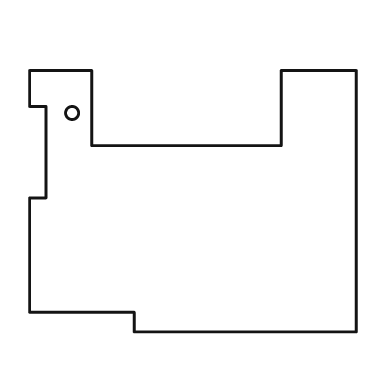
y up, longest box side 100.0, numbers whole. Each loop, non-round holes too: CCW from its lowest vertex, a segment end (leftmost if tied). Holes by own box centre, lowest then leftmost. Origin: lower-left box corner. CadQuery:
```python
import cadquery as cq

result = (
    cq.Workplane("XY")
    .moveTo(32.0, 0.0)
    .lineTo(100.0, 0.0)
    .lineTo(100.0, 80.0)
    .lineTo(77.0, 80.0)
    .lineTo(77.0, 57.0)
    .lineTo(19.0, 57.0)
    .lineTo(19.0, 80.0)
    .lineTo(0.0, 80.0)
    .lineTo(0.0, 69.0)
    .lineTo(5.0, 69.0)
    .lineTo(5.0, 41.0)
    .lineTo(0.0, 41.0)
    .lineTo(0.0, 6.0)
    .lineTo(32.0, 6.0)
    .close()
    .moveTo(13.0, 67.0)
    .circle(2.0)
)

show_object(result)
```